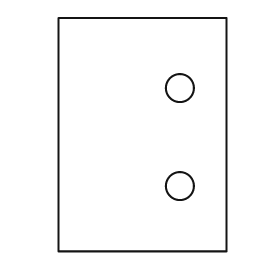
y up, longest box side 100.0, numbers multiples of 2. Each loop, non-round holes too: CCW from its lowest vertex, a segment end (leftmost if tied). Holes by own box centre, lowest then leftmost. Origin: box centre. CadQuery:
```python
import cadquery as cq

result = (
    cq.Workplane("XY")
    .moveTo(-36.0, -50.0)
    .lineTo(36.0, -50.0)
    .lineTo(36.0, 50.0)
    .lineTo(-36.0, 50.0)
    .close()
    .moveTo(16.0, -22.0)
    .circle(6.0)
    .moveTo(16.0, 20.0)
    .circle(6.0)
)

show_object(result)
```